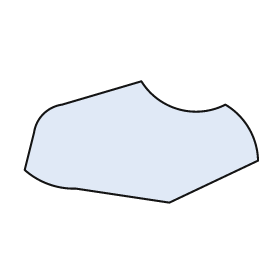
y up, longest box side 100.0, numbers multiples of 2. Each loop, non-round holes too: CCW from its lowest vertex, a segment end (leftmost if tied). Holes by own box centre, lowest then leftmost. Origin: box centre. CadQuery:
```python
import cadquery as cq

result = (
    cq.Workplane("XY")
    .moveTo(12.0, -26.0)
    .lineTo(50.0, -8.0)
    .threePointArc((46.0, 6.0), (36.0, 16.0))
    .threePointArc((16.0, 14.0), (0.0, 26.0))
    .lineTo(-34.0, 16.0)
    .threePointArc((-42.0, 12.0), (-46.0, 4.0))
    .lineTo(-50.0, -12.0)
    .threePointArc((-40.0, -18.0), (-28.0, -20.0))
    .close()
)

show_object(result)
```